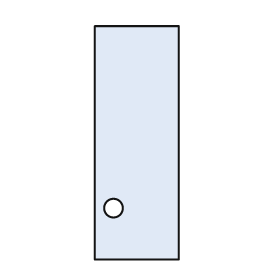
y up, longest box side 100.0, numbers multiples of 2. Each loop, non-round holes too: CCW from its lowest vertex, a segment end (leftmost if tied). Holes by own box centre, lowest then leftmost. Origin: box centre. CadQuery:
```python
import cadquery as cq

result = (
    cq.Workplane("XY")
    .moveTo(-18.0, -50.0)
    .lineTo(18.0, -50.0)
    .lineTo(18.0, 50.0)
    .lineTo(-18.0, 50.0)
    .close()
    .moveTo(-10.0, -28.0)
    .circle(4.0)
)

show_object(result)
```